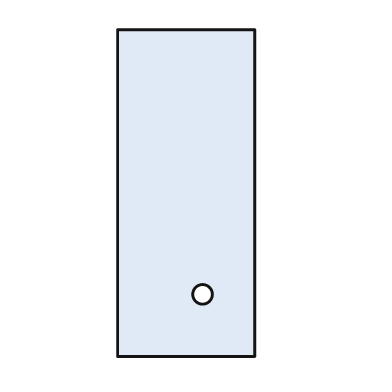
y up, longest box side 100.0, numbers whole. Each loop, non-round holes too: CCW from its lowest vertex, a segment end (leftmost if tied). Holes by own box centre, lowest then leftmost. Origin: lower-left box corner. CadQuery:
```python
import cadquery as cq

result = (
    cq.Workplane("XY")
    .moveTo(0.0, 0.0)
    .lineTo(42.0, 0.0)
    .lineTo(42.0, 100.0)
    .lineTo(0.0, 100.0)
    .close()
    .moveTo(26.0, 19.0)
    .circle(3.0)
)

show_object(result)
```